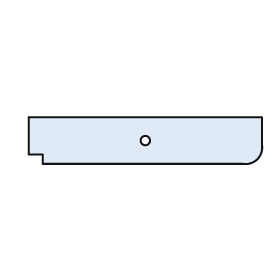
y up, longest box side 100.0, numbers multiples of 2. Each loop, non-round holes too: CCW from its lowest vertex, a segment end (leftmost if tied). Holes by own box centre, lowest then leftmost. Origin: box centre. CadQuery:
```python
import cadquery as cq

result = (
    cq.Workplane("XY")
    .moveTo(-44.0, -10.0)
    .lineTo(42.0, -10.0)
    .threePointArc((48.0, -8.0), (50.0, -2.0))
    .lineTo(50.0, 10.0)
    .lineTo(-50.0, 10.0)
    .lineTo(-50.0, -6.0)
    .lineTo(-44.0, -6.0)
    .close()
    .moveTo(0.0, 0.0)
    .circle(2.0)
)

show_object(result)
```